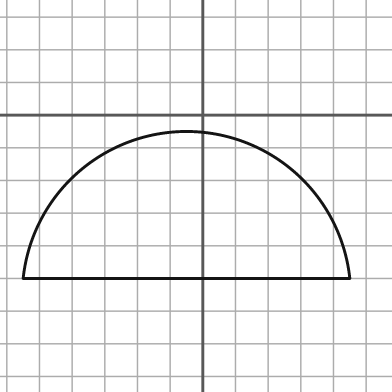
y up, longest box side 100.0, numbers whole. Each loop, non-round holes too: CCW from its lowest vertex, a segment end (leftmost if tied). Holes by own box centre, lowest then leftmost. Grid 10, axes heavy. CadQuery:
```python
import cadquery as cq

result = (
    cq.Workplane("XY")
    .moveTo(-55.0, -50.0)
    .lineTo(45.0, -50.0)
    .threePointArc((-5.0, -5.0), (-55.0, -50.0))
    .close()
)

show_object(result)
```